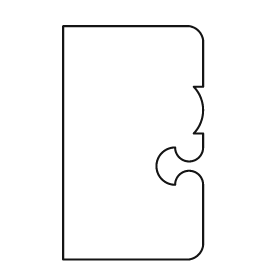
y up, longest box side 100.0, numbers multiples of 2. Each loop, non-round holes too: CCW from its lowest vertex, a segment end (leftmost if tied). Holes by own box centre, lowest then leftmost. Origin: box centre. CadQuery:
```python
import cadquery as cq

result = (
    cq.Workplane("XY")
    .moveTo(-30.0, -50.0)
    .lineTo(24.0, -50.0)
    .threePointArc((28.0, -48.0), (30.0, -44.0))
    .lineTo(30.0, -18.0)
    .threePointArc((24.0, -12.0), (18.0, -18.0))
    .threePointArc((10.0, -10.0), (18.0, -2.0))
    .threePointArc((24.0, -8.0), (30.0, -2.0))
    .lineTo(30.0, 4.0)
    .lineTo(26.0, 4.0)
    .threePointArc((30.0, 14.0), (26.0, 24.0))
    .lineTo(30.0, 24.0)
    .lineTo(30.0, 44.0)
    .threePointArc((28.0, 48.0), (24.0, 50.0))
    .lineTo(-30.0, 50.0)
    .close()
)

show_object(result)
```